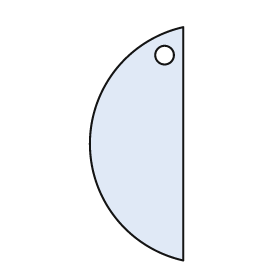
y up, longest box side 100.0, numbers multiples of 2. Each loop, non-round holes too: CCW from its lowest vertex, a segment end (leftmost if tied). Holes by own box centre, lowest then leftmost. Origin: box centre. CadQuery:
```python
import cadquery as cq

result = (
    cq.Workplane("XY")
    .moveTo(20.0, -50.0)
    .lineTo(20.0, 50.0)
    .threePointArc((-20.0, 0.0), (20.0, -50.0))
    .close()
    .moveTo(12.0, 38.0)
    .circle(4.0)
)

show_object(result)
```